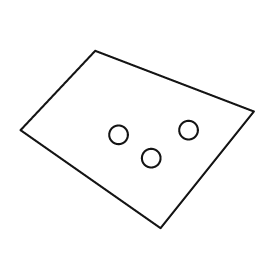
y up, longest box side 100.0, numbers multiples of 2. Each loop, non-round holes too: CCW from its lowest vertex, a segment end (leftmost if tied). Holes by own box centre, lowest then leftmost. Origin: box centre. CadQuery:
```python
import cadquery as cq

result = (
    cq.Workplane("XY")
    .moveTo(10.0, -38.0)
    .lineTo(50.0, 12.0)
    .lineTo(-18.0, 38.0)
    .lineTo(-50.0, 4.0)
    .close()
    .moveTo(6.0, -8.0)
    .circle(4.0)
    .moveTo(-8.0, 2.0)
    .circle(4.0)
    .moveTo(22.0, 4.0)
    .circle(4.0)
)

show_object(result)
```